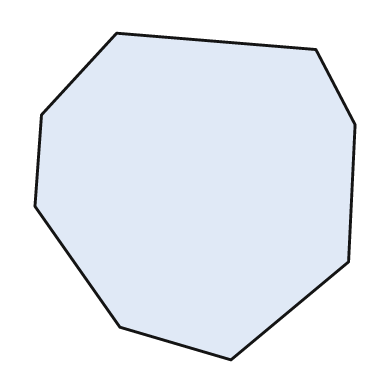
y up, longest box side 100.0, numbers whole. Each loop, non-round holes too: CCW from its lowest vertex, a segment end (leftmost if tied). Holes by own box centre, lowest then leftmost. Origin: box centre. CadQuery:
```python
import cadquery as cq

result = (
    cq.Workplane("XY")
    .moveTo(11.0, -50.0)
    .lineTo(47.0, -20.0)
    .lineTo(49.0, 22.0)
    .lineTo(37.0, 45.0)
    .lineTo(-24.0, 50.0)
    .lineTo(-47.0, 25.0)
    .lineTo(-49.0, -3.0)
    .lineTo(-23.0, -40.0)
    .close()
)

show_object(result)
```